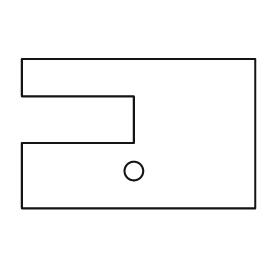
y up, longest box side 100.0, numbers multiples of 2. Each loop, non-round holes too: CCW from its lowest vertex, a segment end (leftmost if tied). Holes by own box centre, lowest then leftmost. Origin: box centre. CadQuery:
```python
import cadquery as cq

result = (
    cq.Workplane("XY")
    .moveTo(-50.0, -32.0)
    .lineTo(50.0, -32.0)
    .lineTo(50.0, 32.0)
    .lineTo(-50.0, 32.0)
    .lineTo(-50.0, 16.0)
    .lineTo(-2.0, 16.0)
    .lineTo(-2.0, -4.0)
    .lineTo(-50.0, -4.0)
    .close()
    .moveTo(-2.0, -16.0)
    .circle(4.0)
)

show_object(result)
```